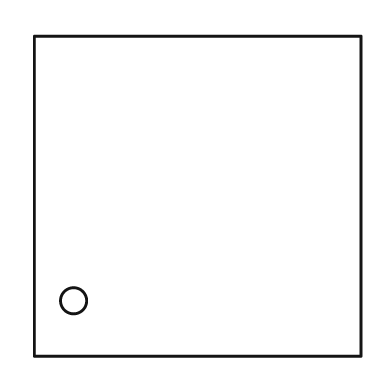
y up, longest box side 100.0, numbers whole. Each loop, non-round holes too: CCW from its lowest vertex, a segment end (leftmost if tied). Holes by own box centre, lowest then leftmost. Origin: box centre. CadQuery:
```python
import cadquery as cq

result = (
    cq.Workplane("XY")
    .moveTo(-50.0, -49.0)
    .lineTo(50.0, -49.0)
    .lineTo(50.0, 49.0)
    .lineTo(-50.0, 49.0)
    .close()
    .moveTo(-38.0, -32.0)
    .circle(4.0)
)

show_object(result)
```